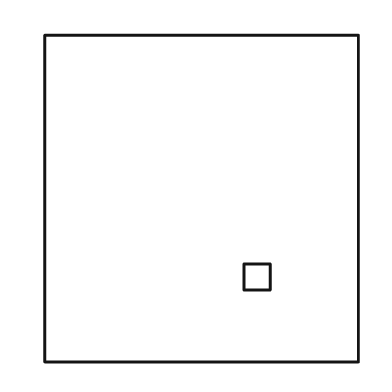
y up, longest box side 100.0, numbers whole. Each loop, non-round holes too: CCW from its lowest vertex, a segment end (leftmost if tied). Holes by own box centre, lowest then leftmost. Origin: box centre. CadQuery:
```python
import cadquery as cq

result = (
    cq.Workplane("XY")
    .moveTo(-48.0, -50.0)
    .lineTo(48.0, -50.0)
    .lineTo(48.0, 50.0)
    .lineTo(-48.0, 50.0)
    .close()
    .moveTo(13.0, -28.0)
    .lineTo(21.0, -28.0)
    .lineTo(21.0, -20.0)
    .lineTo(13.0, -20.0)
    .close()
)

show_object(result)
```